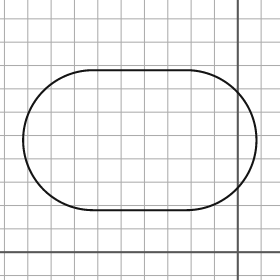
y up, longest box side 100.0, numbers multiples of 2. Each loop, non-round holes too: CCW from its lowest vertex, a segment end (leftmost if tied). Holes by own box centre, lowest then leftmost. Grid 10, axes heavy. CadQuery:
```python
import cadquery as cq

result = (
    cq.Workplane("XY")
    .moveTo(-62.0, 18.0)
    .lineTo(-22.0, 18.0)
    .threePointArc((8.0, 48.0), (-22.0, 78.0))
    .lineTo(-62.0, 78.0)
    .threePointArc((-92.0, 48.0), (-62.0, 18.0))
    .close()
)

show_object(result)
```